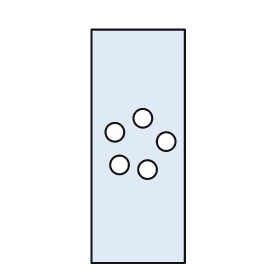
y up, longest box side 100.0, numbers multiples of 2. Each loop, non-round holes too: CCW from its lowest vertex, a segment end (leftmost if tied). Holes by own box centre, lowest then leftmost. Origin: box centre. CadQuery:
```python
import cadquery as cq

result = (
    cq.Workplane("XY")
    .moveTo(-20.0, -50.0)
    .lineTo(20.0, -50.0)
    .lineTo(20.0, 50.0)
    .lineTo(-20.0, 50.0)
    .close()
    .moveTo(4.0, -10.0)
    .circle(4.0)
    .moveTo(-8.0, -8.0)
    .circle(4.0)
    .moveTo(12.0, 2.0)
    .circle(4.0)
    .moveTo(-10.0, 6.0)
    .circle(4.0)
    .moveTo(2.0, 12.0)
    .circle(4.0)
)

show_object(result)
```